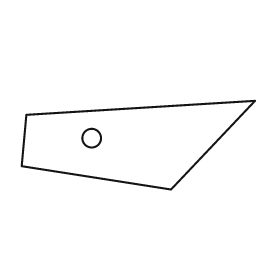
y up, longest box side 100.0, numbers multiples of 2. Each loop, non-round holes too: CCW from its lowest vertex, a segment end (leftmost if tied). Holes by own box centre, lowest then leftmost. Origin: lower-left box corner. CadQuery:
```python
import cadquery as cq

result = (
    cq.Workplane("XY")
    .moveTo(64.0, 0.0)
    .lineTo(100.0, 38.0)
    .lineTo(2.0, 32.0)
    .lineTo(0.0, 10.0)
    .close()
    .moveTo(30.0, 22.0)
    .circle(4.0)
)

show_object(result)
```